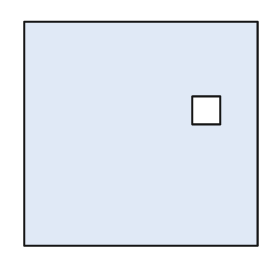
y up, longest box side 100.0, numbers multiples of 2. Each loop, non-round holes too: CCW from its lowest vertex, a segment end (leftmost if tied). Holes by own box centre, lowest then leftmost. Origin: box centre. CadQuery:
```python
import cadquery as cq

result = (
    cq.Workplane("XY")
    .moveTo(-50.0, -48.0)
    .lineTo(50.0, -48.0)
    .lineTo(50.0, 48.0)
    .lineTo(-50.0, 48.0)
    .close()
    .moveTo(22.0, 4.0)
    .lineTo(34.0, 4.0)
    .lineTo(34.0, 16.0)
    .lineTo(22.0, 16.0)
    .close()
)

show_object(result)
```